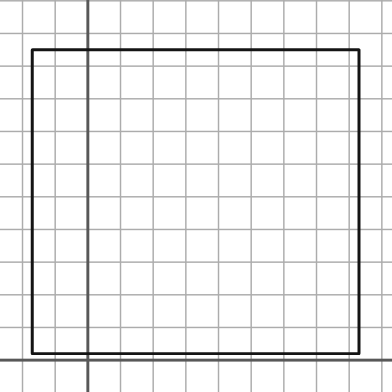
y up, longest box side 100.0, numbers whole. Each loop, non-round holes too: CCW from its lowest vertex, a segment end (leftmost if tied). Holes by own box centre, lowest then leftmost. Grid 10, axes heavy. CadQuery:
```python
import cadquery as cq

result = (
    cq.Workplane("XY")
    .moveTo(-17.0, 2.0)
    .lineTo(83.0, 2.0)
    .lineTo(83.0, 95.0)
    .lineTo(-17.0, 95.0)
    .close()
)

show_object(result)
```